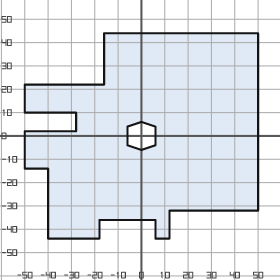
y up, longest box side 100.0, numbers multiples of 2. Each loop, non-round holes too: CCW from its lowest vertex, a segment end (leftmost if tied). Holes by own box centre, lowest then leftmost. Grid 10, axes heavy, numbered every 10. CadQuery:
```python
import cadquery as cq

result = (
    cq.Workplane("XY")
    .moveTo(-40.0, -44.0)
    .lineTo(-18.0, -44.0)
    .lineTo(-18.0, -36.0)
    .lineTo(6.0, -36.0)
    .lineTo(6.0, -44.0)
    .lineTo(12.0, -44.0)
    .lineTo(12.0, -32.0)
    .lineTo(50.0, -32.0)
    .lineTo(50.0, 44.0)
    .lineTo(-16.0, 44.0)
    .lineTo(-16.0, 22.0)
    .lineTo(-50.0, 22.0)
    .lineTo(-50.0, 10.0)
    .lineTo(-28.0, 10.0)
    .lineTo(-28.0, 2.0)
    .lineTo(-50.0, 2.0)
    .lineTo(-50.0, -14.0)
    .lineTo(-40.0, -14.0)
    .close()
    .moveTo(0.0, -6.0)
    .lineTo(6.0, -4.0)
    .lineTo(6.0, 4.0)
    .lineTo(0.0, 6.0)
    .lineTo(-6.0, 4.0)
    .lineTo(-6.0, -4.0)
    .close()
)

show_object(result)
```